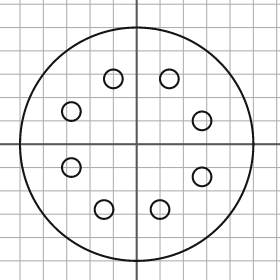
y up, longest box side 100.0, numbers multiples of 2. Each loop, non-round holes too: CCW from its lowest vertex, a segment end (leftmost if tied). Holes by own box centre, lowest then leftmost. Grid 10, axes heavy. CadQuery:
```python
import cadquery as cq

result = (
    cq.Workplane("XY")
    .moveTo(0.0, 0.0)
    .circle(50.0)
    .moveTo(-14.0, -28.0)
    .circle(4.0)
    .moveTo(10.0, -28.0)
    .circle(4.0)
    .moveTo(28.0, -14.0)
    .circle(4.0)
    .moveTo(-28.0, -10.0)
    .circle(4.0)
    .moveTo(28.0, 10.0)
    .circle(4.0)
    .moveTo(-28.0, 14.0)
    .circle(4.0)
    .moveTo(-10.0, 28.0)
    .circle(4.0)
    .moveTo(14.0, 28.0)
    .circle(4.0)
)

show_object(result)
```